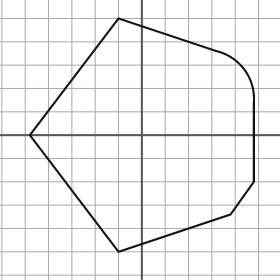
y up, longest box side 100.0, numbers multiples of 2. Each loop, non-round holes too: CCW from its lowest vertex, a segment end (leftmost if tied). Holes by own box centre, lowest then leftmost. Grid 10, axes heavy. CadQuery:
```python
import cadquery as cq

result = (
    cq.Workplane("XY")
    .moveTo(-10.0, -50.0)
    .lineTo(38.0, -34.0)
    .lineTo(48.0, -20.0)
    .lineTo(48.0, 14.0)
    .threePointArc((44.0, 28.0), (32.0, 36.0))
    .lineTo(-10.0, 50.0)
    .lineTo(-48.0, 0.0)
    .close()
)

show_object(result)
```